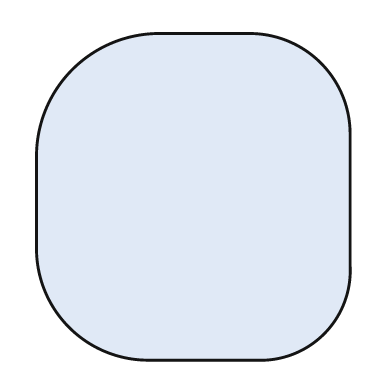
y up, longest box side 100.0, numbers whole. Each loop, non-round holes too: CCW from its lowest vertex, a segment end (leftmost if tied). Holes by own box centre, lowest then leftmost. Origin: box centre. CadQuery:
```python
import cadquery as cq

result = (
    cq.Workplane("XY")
    .moveTo(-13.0, -50.0)
    .lineTo(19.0, -50.0)
    .threePointArc((40.0, -42.0), (48.0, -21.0))
    .lineTo(48.0, 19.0)
    .threePointArc((39.0, 41.0), (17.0, 50.0))
    .lineTo(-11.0, 50.0)
    .threePointArc((-37.0, 39.0), (-48.0, 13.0))
    .lineTo(-48.0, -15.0)
    .threePointArc((-38.0, -40.0), (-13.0, -50.0))
    .close()
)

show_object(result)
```